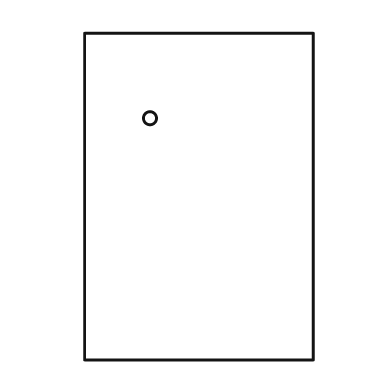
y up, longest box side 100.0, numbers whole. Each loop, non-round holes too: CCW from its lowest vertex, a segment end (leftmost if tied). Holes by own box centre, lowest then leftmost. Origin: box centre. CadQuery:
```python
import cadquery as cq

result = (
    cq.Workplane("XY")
    .moveTo(-35.0, -50.0)
    .lineTo(35.0, -50.0)
    .lineTo(35.0, 50.0)
    .lineTo(-35.0, 50.0)
    .close()
    .moveTo(-15.0, 24.0)
    .circle(2.0)
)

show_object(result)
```